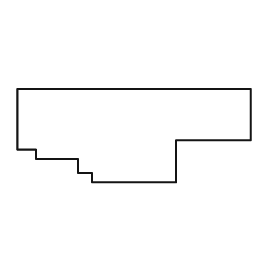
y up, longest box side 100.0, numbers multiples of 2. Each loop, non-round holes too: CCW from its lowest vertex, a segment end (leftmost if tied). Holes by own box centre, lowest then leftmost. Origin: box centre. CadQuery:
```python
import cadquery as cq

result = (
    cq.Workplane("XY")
    .moveTo(-18.0, -20.0)
    .lineTo(18.0, -20.0)
    .lineTo(18.0, -2.0)
    .lineTo(50.0, -2.0)
    .lineTo(50.0, 20.0)
    .lineTo(-50.0, 20.0)
    .lineTo(-50.0, -6.0)
    .lineTo(-42.0, -6.0)
    .lineTo(-42.0, -10.0)
    .lineTo(-24.0, -10.0)
    .lineTo(-24.0, -16.0)
    .lineTo(-18.0, -16.0)
    .close()
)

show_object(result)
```